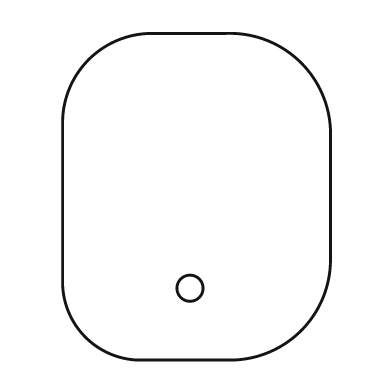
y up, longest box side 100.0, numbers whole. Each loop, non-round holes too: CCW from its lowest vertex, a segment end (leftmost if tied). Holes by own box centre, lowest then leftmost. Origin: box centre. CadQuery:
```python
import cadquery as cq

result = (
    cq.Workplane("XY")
    .moveTo(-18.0, -50.0)
    .lineTo(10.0, -50.0)
    .threePointArc((32.0, -41.0), (41.0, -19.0))
    .lineTo(41.0, 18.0)
    .threePointArc((32.0, 41.0), (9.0, 50.0))
    .lineTo(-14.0, 50.0)
    .threePointArc((-33.0, 42.0), (-41.0, 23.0))
    .lineTo(-41.0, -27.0)
    .threePointArc((-34.0, -43.0), (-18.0, -50.0))
    .close()
    .moveTo(-2.0, -28.0)
    .circle(4.0)
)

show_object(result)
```